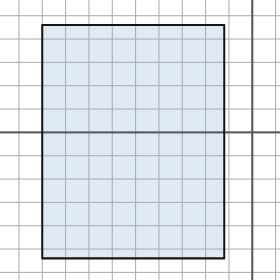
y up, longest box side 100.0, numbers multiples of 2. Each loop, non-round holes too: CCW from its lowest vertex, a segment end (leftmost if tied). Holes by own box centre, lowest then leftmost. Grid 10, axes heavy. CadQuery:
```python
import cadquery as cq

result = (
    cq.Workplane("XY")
    .moveTo(-90.0, -54.0)
    .lineTo(-12.0, -54.0)
    .lineTo(-12.0, 46.0)
    .lineTo(-90.0, 46.0)
    .close()
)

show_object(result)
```